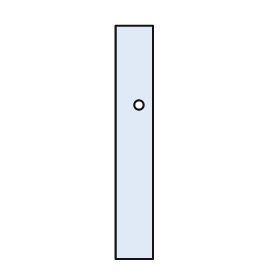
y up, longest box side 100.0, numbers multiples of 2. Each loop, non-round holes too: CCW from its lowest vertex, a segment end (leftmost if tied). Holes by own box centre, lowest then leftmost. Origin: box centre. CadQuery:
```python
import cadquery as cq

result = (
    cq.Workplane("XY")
    .moveTo(-8.0, -50.0)
    .lineTo(8.0, -50.0)
    .lineTo(8.0, 50.0)
    .lineTo(-8.0, 50.0)
    .close()
    .moveTo(2.0, 16.0)
    .circle(2.0)
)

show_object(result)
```